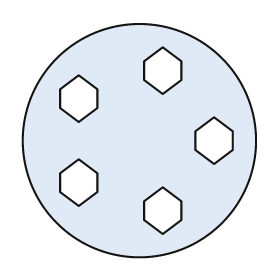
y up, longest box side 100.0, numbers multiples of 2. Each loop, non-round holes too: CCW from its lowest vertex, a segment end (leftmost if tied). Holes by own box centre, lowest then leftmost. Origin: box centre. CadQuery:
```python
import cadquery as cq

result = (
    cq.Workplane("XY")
    .moveTo(0.0, 0.0)
    .circle(50.0)
    .moveTo(10.0, -40.0)
    .lineTo(18.0, -34.0)
    .lineTo(18.0, -26.0)
    .lineTo(10.0, -20.0)
    .lineTo(2.0, -26.0)
    .lineTo(2.0, -34.0)
    .close()
    .moveTo(-26.0, -28.0)
    .lineTo(-18.0, -22.0)
    .lineTo(-18.0, -14.0)
    .lineTo(-26.0, -8.0)
    .lineTo(-34.0, -14.0)
    .lineTo(-34.0, -22.0)
    .close()
    .moveTo(32.0, -10.0)
    .lineTo(40.0, -4.0)
    .lineTo(40.0, 4.0)
    .lineTo(32.0, 10.0)
    .lineTo(24.0, 4.0)
    .lineTo(24.0, -4.0)
    .close()
    .moveTo(-26.0, 8.0)
    .lineTo(-18.0, 14.0)
    .lineTo(-18.0, 22.0)
    .lineTo(-26.0, 28.0)
    .lineTo(-34.0, 22.0)
    .lineTo(-34.0, 14.0)
    .close()
    .moveTo(10.0, 20.0)
    .lineTo(18.0, 26.0)
    .lineTo(18.0, 34.0)
    .lineTo(10.0, 40.0)
    .lineTo(2.0, 34.0)
    .lineTo(2.0, 26.0)
    .close()
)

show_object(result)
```